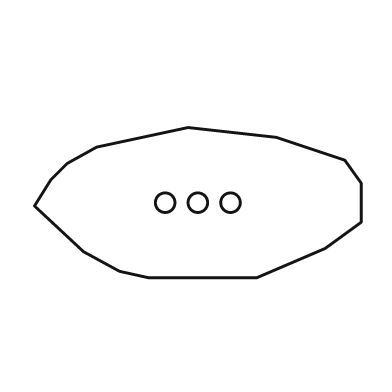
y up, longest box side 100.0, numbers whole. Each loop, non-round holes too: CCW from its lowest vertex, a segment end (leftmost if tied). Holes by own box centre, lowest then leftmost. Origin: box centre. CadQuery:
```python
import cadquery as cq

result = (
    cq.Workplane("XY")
    .moveTo(-15.0, -23.0)
    .lineTo(18.0, -23.0)
    .lineTo(39.0, -14.0)
    .lineTo(50.0, -6.0)
    .lineTo(50.0, 6.0)
    .lineTo(45.0, 13.0)
    .lineTo(24.0, 20.0)
    .lineTo(-3.0, 23.0)
    .lineTo(-31.0, 17.0)
    .lineTo(-40.0, 12.0)
    .lineTo(-45.0, 7.0)
    .lineTo(-50.0, -1.0)
    .lineTo(-35.0, -15.0)
    .lineTo(-24.0, -21.0)
    .close()
    .moveTo(-10.0, 0.0)
    .circle(3.0)
    .moveTo(0.0, 0.0)
    .circle(3.0)
    .moveTo(10.0, 0.0)
    .circle(3.0)
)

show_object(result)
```